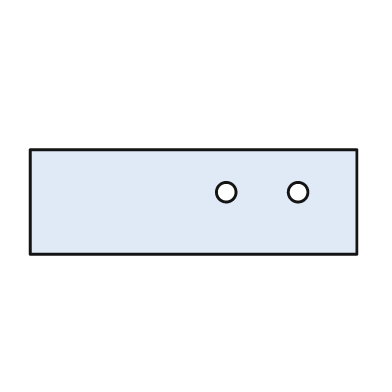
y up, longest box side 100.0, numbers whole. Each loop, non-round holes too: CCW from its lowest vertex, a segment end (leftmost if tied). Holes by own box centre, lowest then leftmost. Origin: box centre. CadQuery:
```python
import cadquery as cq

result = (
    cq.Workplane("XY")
    .moveTo(-50.0, -16.0)
    .lineTo(50.0, -16.0)
    .lineTo(50.0, 16.0)
    .lineTo(-50.0, 16.0)
    .close()
    .moveTo(10.0, 3.0)
    .circle(3.0)
    .moveTo(32.0, 3.0)
    .circle(3.0)
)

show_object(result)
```